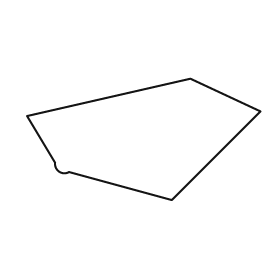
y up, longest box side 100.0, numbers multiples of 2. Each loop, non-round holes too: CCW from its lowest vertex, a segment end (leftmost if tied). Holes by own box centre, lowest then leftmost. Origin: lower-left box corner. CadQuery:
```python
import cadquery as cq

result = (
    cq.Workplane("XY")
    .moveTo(62.0, 0.0)
    .lineTo(100.0, 38.0)
    .lineTo(70.0, 52.0)
    .lineTo(0.0, 36.0)
    .lineTo(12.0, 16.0)
    .threePointArc((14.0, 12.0), (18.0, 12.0))
    .close()
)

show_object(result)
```